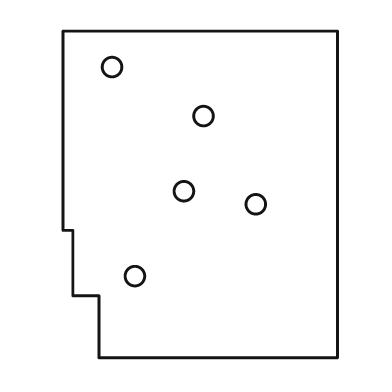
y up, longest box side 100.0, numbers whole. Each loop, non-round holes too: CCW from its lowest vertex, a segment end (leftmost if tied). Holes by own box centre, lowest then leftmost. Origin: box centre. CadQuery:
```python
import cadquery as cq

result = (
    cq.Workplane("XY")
    .moveTo(-31.0, -50.0)
    .lineTo(42.0, -50.0)
    .lineTo(42.0, 50.0)
    .lineTo(-42.0, 50.0)
    .lineTo(-42.0, -11.0)
    .lineTo(-39.0, -11.0)
    .lineTo(-39.0, -31.0)
    .lineTo(-31.0, -31.0)
    .close()
    .moveTo(-20.0, -25.0)
    .circle(3.0)
    .moveTo(17.0, -3.0)
    .circle(3.0)
    .moveTo(-5.0, 1.0)
    .circle(3.0)
    .moveTo(1.0, 24.0)
    .circle(3.0)
    .moveTo(-27.0, 39.0)
    .circle(3.0)
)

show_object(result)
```